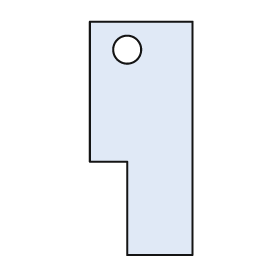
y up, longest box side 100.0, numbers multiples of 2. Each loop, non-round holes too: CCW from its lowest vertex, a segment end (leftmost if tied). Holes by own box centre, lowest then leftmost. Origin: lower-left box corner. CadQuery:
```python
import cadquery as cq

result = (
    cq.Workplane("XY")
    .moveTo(16.0, 0.0)
    .lineTo(44.0, 0.0)
    .lineTo(44.0, 100.0)
    .lineTo(0.0, 100.0)
    .lineTo(0.0, 40.0)
    .lineTo(16.0, 40.0)
    .close()
    .moveTo(16.0, 88.0)
    .circle(6.0)
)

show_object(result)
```